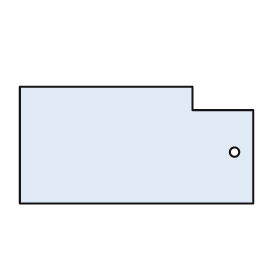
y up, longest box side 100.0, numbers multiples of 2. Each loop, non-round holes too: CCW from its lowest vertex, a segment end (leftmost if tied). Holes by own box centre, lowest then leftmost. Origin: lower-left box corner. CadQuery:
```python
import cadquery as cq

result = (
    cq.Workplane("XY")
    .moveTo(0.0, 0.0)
    .lineTo(100.0, 0.0)
    .lineTo(100.0, 40.0)
    .lineTo(74.0, 40.0)
    .lineTo(74.0, 50.0)
    .lineTo(0.0, 50.0)
    .close()
    .moveTo(92.0, 22.0)
    .circle(2.0)
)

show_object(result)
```